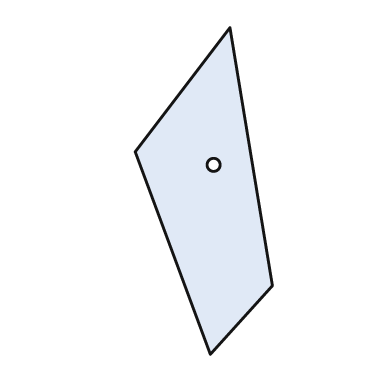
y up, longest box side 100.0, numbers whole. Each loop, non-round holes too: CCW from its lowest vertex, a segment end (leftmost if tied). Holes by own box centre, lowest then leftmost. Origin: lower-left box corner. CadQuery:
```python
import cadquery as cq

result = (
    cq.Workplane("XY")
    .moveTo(23.0, 0.0)
    .lineTo(42.0, 21.0)
    .lineTo(29.0, 100.0)
    .lineTo(0.0, 62.0)
    .close()
    .moveTo(24.0, 58.0)
    .circle(2.0)
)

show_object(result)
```